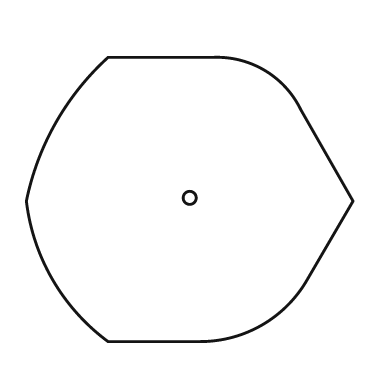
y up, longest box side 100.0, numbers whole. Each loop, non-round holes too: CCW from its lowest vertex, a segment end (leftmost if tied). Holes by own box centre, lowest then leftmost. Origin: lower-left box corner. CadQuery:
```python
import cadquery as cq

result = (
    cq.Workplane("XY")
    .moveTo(25.0, 0.0)
    .lineTo(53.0, 0.0)
    .threePointArc((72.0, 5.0), (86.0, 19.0))
    .lineTo(100.0, 43.0)
    .lineTo(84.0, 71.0)
    .threePointArc((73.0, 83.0), (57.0, 87.0))
    .lineTo(25.0, 87.0)
    .threePointArc((9.0, 67.0), (0.0, 43.0))
    .threePointArc((8.0, 19.0), (25.0, 0.0))
    .close()
    .moveTo(50.0, 44.0)
    .circle(2.0)
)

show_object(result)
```